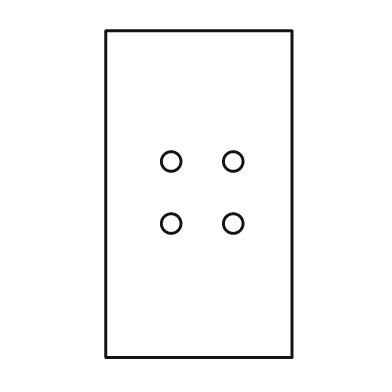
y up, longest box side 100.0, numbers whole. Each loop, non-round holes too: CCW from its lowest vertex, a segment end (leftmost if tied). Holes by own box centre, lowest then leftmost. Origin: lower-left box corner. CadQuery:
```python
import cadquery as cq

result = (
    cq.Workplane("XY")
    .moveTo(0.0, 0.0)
    .lineTo(57.0, 0.0)
    .lineTo(57.0, 100.0)
    .lineTo(0.0, 100.0)
    .close()
    .moveTo(20.0, 41.0)
    .circle(3.0)
    .moveTo(39.0, 41.0)
    .circle(3.0)
    .moveTo(20.0, 60.0)
    .circle(3.0)
    .moveTo(39.0, 60.0)
    .circle(3.0)
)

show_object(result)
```